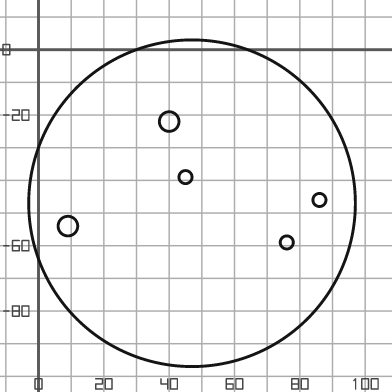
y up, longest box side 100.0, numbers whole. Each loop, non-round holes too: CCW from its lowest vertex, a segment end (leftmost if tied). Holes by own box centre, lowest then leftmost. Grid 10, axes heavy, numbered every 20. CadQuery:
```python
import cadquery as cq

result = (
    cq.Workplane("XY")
    .moveTo(47.0, -47.0)
    .circle(50.0)
    .moveTo(76.0, -59.0)
    .circle(2.0)
    .moveTo(9.0, -54.0)
    .circle(3.0)
    .moveTo(86.0, -46.0)
    .circle(2.0)
    .moveTo(45.0, -39.0)
    .circle(2.0)
    .moveTo(40.0, -22.0)
    .circle(3.0)
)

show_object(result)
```